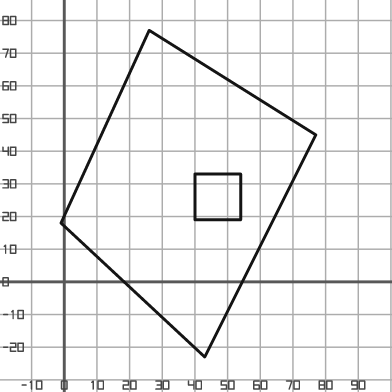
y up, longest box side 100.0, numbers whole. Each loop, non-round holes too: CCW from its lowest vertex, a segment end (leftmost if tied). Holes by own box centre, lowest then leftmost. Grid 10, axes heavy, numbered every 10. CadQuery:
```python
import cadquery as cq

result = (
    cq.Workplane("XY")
    .moveTo(43.0, -23.0)
    .lineTo(77.0, 45.0)
    .lineTo(26.0, 77.0)
    .lineTo(-1.0, 18.0)
    .close()
    .moveTo(40.0, 19.0)
    .lineTo(54.0, 19.0)
    .lineTo(54.0, 33.0)
    .lineTo(40.0, 33.0)
    .close()
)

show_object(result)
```